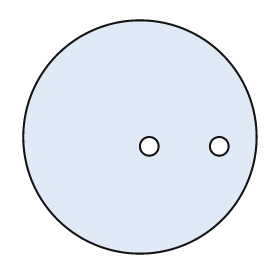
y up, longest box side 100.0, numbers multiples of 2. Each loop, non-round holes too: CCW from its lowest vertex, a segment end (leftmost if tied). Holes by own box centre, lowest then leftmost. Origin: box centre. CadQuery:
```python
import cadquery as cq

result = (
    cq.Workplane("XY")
    .moveTo(0.0, 0.0)
    .circle(50.0)
    .moveTo(4.0, -4.0)
    .circle(4.0)
    .moveTo(34.0, -4.0)
    .circle(4.0)
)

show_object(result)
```